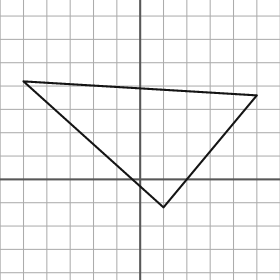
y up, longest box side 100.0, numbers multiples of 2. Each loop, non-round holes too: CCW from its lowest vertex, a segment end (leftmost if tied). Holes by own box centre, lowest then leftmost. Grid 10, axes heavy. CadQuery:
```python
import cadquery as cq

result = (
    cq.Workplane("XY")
    .moveTo(10.0, -12.0)
    .lineTo(50.0, 36.0)
    .lineTo(-50.0, 42.0)
    .close()
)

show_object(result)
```